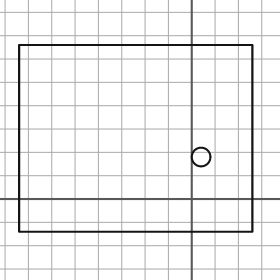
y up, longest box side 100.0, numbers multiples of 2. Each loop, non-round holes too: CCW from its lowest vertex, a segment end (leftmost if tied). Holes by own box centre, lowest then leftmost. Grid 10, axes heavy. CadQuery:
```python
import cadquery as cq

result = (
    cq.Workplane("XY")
    .moveTo(-74.0, -14.0)
    .lineTo(26.0, -14.0)
    .lineTo(26.0, 66.0)
    .lineTo(-74.0, 66.0)
    .close()
    .moveTo(4.0, 18.0)
    .circle(4.0)
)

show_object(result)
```